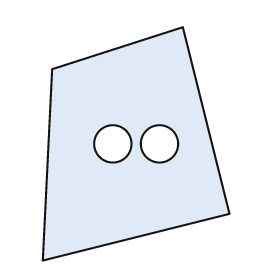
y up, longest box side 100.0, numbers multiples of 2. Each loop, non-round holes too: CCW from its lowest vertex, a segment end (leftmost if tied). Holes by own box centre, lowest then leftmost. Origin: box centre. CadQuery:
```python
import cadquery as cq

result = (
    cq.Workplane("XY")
    .moveTo(-40.0, -50.0)
    .lineTo(40.0, -30.0)
    .lineTo(20.0, 50.0)
    .lineTo(-36.0, 32.0)
    .close()
    .moveTo(-10.0, 0.0)
    .circle(8.0)
    .moveTo(10.0, 0.0)
    .circle(8.0)
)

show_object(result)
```